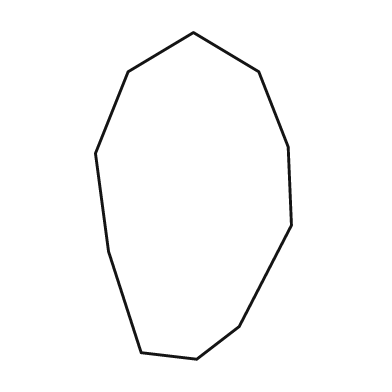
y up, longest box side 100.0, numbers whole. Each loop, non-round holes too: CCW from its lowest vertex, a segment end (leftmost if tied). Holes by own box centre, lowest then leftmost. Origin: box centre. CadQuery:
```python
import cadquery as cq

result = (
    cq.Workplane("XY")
    .moveTo(1.0, -50.0)
    .lineTo(14.0, -40.0)
    .lineTo(30.0, -9.0)
    .lineTo(29.0, 15.0)
    .lineTo(20.0, 38.0)
    .lineTo(0.0, 50.0)
    .lineTo(-20.0, 38.0)
    .lineTo(-30.0, 13.0)
    .lineTo(-26.0, -17.0)
    .lineTo(-16.0, -48.0)
    .close()
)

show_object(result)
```